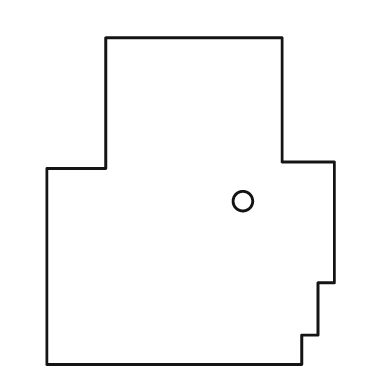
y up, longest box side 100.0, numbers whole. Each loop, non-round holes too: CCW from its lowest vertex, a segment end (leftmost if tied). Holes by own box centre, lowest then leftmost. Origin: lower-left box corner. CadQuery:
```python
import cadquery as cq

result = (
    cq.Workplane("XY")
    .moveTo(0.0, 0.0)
    .lineTo(78.0, 0.0)
    .lineTo(78.0, 9.0)
    .lineTo(83.0, 9.0)
    .lineTo(83.0, 25.0)
    .lineTo(88.0, 25.0)
    .lineTo(88.0, 62.0)
    .lineTo(72.0, 62.0)
    .lineTo(72.0, 100.0)
    .lineTo(18.0, 100.0)
    .lineTo(18.0, 60.0)
    .lineTo(0.0, 60.0)
    .close()
    .moveTo(60.0, 50.0)
    .circle(3.0)
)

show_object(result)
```